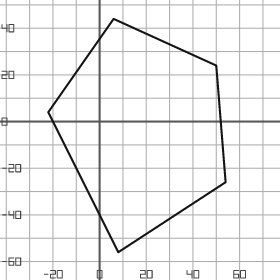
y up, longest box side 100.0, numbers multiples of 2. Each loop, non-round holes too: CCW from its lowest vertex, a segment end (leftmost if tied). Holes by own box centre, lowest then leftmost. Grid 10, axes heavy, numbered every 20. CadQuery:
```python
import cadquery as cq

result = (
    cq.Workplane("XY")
    .moveTo(8.0, -56.0)
    .lineTo(54.0, -26.0)
    .lineTo(50.0, 24.0)
    .lineTo(6.0, 44.0)
    .lineTo(-22.0, 4.0)
    .close()
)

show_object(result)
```